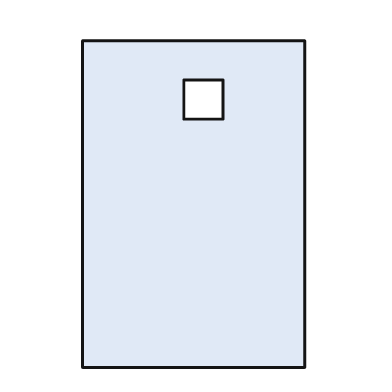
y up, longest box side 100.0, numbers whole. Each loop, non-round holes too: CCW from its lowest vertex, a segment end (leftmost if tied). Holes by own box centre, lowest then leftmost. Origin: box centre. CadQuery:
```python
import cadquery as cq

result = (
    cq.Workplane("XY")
    .moveTo(-34.0, -50.0)
    .lineTo(34.0, -50.0)
    .lineTo(34.0, 50.0)
    .lineTo(-34.0, 50.0)
    .close()
    .moveTo(-3.0, 26.0)
    .lineTo(9.0, 26.0)
    .lineTo(9.0, 38.0)
    .lineTo(-3.0, 38.0)
    .close()
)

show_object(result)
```